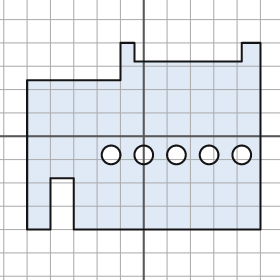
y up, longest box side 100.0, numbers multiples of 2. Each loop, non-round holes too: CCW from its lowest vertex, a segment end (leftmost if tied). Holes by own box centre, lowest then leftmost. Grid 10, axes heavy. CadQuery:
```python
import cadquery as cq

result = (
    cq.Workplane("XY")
    .moveTo(-50.0, -40.0)
    .lineTo(-40.0, -40.0)
    .lineTo(-40.0, -18.0)
    .lineTo(-30.0, -18.0)
    .lineTo(-30.0, -40.0)
    .lineTo(50.0, -40.0)
    .lineTo(50.0, 40.0)
    .lineTo(42.0, 40.0)
    .lineTo(42.0, 32.0)
    .lineTo(-4.0, 32.0)
    .lineTo(-4.0, 40.0)
    .lineTo(-10.0, 40.0)
    .lineTo(-10.0, 24.0)
    .lineTo(-50.0, 24.0)
    .close()
    .moveTo(-14.0, -8.0)
    .circle(4.0)
    .moveTo(0.0, -8.0)
    .circle(4.0)
    .moveTo(14.0, -8.0)
    .circle(4.0)
    .moveTo(28.0, -8.0)
    .circle(4.0)
    .moveTo(42.0, -8.0)
    .circle(4.0)
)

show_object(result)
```